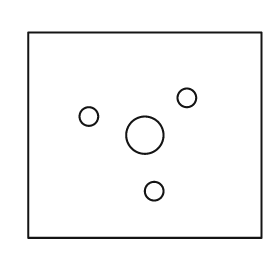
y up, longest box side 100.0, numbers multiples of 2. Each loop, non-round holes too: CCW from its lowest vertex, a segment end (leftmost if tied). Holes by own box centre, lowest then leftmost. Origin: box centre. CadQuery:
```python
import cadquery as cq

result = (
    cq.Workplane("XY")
    .moveTo(-50.0, -44.0)
    .lineTo(50.0, -44.0)
    .lineTo(50.0, 44.0)
    .lineTo(-50.0, 44.0)
    .close()
    .moveTo(4.0, -24.0)
    .circle(4.0)
    .moveTo(0.0, 0.0)
    .circle(8.0)
    .moveTo(-24.0, 8.0)
    .circle(4.0)
    .moveTo(18.0, 16.0)
    .circle(4.0)
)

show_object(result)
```